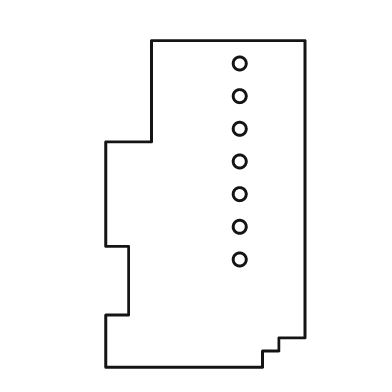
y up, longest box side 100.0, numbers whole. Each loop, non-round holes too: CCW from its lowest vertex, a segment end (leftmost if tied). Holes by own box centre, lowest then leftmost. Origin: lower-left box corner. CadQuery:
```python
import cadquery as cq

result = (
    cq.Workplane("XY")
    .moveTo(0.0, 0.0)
    .lineTo(48.0, 0.0)
    .lineTo(48.0, 5.0)
    .lineTo(53.0, 5.0)
    .lineTo(53.0, 9.0)
    .lineTo(61.0, 9.0)
    .lineTo(61.0, 100.0)
    .lineTo(14.0, 100.0)
    .lineTo(14.0, 69.0)
    .lineTo(0.0, 69.0)
    .lineTo(0.0, 37.0)
    .lineTo(7.0, 37.0)
    .lineTo(7.0, 16.0)
    .lineTo(0.0, 16.0)
    .close()
    .moveTo(41.0, 33.0)
    .circle(2.0)
    .moveTo(41.0, 43.0)
    .circle(2.0)
    .moveTo(41.0, 53.0)
    .circle(2.0)
    .moveTo(41.0, 63.0)
    .circle(2.0)
    .moveTo(41.0, 73.0)
    .circle(2.0)
    .moveTo(41.0, 83.0)
    .circle(2.0)
    .moveTo(41.0, 93.0)
    .circle(2.0)
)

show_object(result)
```